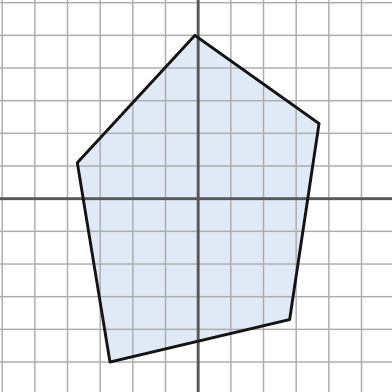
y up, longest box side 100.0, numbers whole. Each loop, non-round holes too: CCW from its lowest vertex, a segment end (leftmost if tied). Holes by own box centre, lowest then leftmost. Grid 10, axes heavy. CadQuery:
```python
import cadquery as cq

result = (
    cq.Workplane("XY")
    .moveTo(-27.0, -50.0)
    .lineTo(28.0, -37.0)
    .lineTo(37.0, 23.0)
    .lineTo(-1.0, 50.0)
    .lineTo(-37.0, 11.0)
    .close()
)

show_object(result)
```